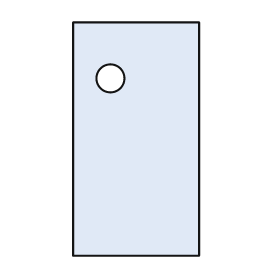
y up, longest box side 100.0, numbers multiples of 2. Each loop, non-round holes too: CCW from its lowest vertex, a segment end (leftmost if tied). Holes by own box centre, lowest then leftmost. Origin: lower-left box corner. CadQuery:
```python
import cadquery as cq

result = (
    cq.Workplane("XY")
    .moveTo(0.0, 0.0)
    .lineTo(54.0, 0.0)
    .lineTo(54.0, 100.0)
    .lineTo(0.0, 100.0)
    .close()
    .moveTo(16.0, 76.0)
    .circle(6.0)
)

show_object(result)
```